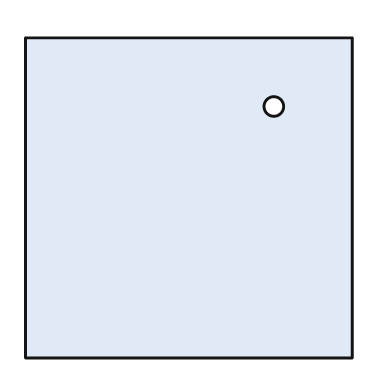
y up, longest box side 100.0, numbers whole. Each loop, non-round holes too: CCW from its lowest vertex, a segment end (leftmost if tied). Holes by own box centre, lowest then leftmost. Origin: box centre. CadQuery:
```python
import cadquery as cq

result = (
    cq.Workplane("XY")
    .moveTo(-50.0, -49.0)
    .lineTo(50.0, -49.0)
    .lineTo(50.0, 49.0)
    .lineTo(-50.0, 49.0)
    .close()
    .moveTo(26.0, 28.0)
    .circle(3.0)
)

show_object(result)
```